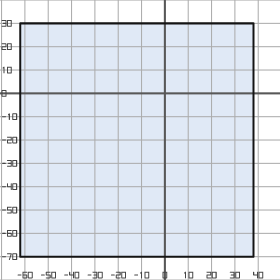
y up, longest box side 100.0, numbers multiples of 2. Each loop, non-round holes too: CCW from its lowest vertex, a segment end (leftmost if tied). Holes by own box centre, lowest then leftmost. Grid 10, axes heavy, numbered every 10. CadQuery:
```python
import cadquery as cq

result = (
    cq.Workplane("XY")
    .moveTo(-62.0, -70.0)
    .lineTo(38.0, -70.0)
    .lineTo(38.0, 30.0)
    .lineTo(-62.0, 30.0)
    .close()
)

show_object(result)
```